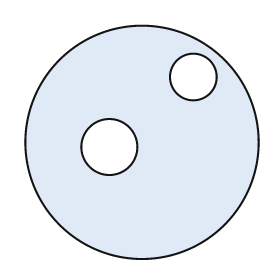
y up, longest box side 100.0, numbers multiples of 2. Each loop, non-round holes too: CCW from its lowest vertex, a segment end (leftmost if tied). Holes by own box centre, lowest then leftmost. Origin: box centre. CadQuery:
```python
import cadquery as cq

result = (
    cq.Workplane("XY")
    .moveTo(0.0, 0.0)
    .circle(50.0)
    .moveTo(-14.0, -2.0)
    .circle(12.0)
    .moveTo(22.0, 28.0)
    .circle(10.0)
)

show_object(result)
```